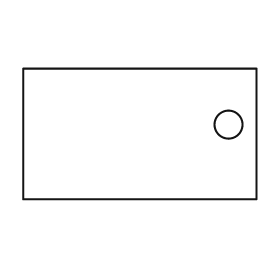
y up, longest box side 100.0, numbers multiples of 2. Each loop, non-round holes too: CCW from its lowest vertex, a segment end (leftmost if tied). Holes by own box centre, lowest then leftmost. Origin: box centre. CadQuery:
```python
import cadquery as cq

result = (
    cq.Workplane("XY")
    .moveTo(-50.0, -28.0)
    .lineTo(50.0, -28.0)
    .lineTo(50.0, 28.0)
    .lineTo(-50.0, 28.0)
    .close()
    .moveTo(38.0, 4.0)
    .circle(6.0)
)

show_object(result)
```